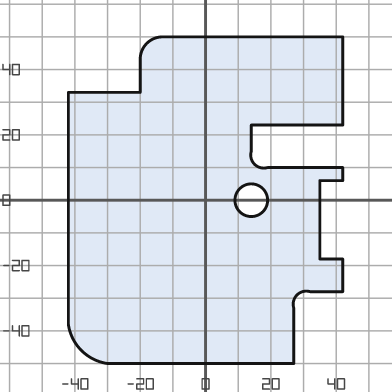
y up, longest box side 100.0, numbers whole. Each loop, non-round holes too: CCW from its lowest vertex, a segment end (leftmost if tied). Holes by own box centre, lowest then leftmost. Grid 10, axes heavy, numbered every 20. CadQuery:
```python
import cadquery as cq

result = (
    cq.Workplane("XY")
    .moveTo(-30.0, -50.0)
    .lineTo(27.0, -50.0)
    .lineTo(27.0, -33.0)
    .threePointArc((28.0, -29.0), (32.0, -28.0))
    .lineTo(42.0, -28.0)
    .lineTo(42.0, -18.0)
    .lineTo(35.0, -18.0)
    .lineTo(35.0, 6.0)
    .lineTo(42.0, 6.0)
    .lineTo(42.0, 10.0)
    .lineTo(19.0, 10.0)
    .threePointArc((15.0, 11.0), (14.0, 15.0))
    .lineTo(14.0, 23.0)
    .lineTo(42.0, 23.0)
    .lineTo(42.0, 50.0)
    .lineTo(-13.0, 50.0)
    .threePointArc((-18.0, 48.0), (-20.0, 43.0))
    .lineTo(-20.0, 33.0)
    .lineTo(-42.0, 33.0)
    .lineTo(-42.0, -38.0)
    .threePointArc((-38.0, -46.0), (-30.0, -50.0))
    .close()
    .moveTo(14.0, 0.0)
    .circle(5.0)
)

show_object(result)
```